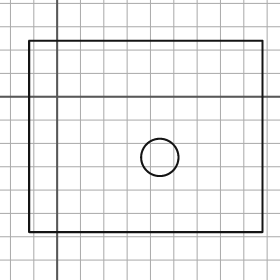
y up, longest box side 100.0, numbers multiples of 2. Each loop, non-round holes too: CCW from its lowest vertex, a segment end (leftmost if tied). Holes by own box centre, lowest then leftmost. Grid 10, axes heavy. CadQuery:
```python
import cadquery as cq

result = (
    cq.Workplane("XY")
    .moveTo(-12.0, -58.0)
    .lineTo(88.0, -58.0)
    .lineTo(88.0, 24.0)
    .lineTo(-12.0, 24.0)
    .close()
    .moveTo(44.0, -26.0)
    .circle(8.0)
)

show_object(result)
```